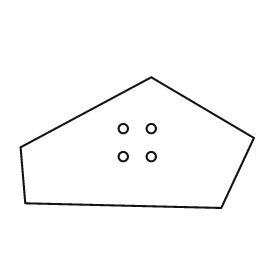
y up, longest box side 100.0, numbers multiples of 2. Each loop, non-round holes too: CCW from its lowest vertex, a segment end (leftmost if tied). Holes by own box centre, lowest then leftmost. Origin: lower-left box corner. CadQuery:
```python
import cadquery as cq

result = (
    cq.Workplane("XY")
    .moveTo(86.0, 0.0)
    .lineTo(100.0, 30.0)
    .lineTo(56.0, 56.0)
    .lineTo(0.0, 26.0)
    .lineTo(2.0, 2.0)
    .close()
    .moveTo(44.0, 22.0)
    .circle(2.0)
    .moveTo(56.0, 22.0)
    .circle(2.0)
    .moveTo(44.0, 34.0)
    .circle(2.0)
    .moveTo(56.0, 34.0)
    .circle(2.0)
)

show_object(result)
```